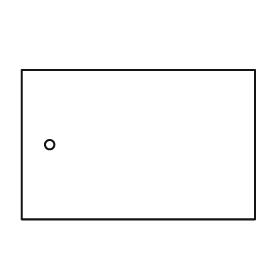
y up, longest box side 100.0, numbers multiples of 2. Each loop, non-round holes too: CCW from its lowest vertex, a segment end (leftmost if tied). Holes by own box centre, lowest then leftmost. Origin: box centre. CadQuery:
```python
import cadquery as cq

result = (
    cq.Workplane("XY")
    .moveTo(-50.0, -32.0)
    .lineTo(50.0, -32.0)
    .lineTo(50.0, 32.0)
    .lineTo(-50.0, 32.0)
    .close()
    .moveTo(-38.0, 0.0)
    .circle(2.0)
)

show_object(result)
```